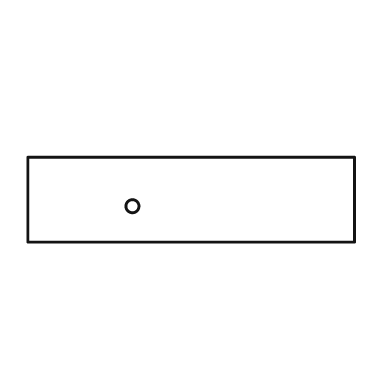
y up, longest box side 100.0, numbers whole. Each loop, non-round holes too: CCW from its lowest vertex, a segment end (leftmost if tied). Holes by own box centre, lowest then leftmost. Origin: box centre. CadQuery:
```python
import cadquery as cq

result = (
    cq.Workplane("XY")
    .moveTo(-50.0, -13.0)
    .lineTo(50.0, -13.0)
    .lineTo(50.0, 13.0)
    .lineTo(-50.0, 13.0)
    .close()
    .moveTo(-18.0, -2.0)
    .circle(2.0)
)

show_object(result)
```